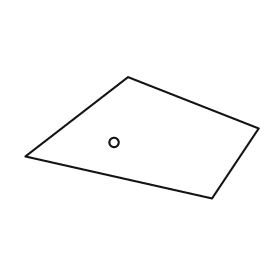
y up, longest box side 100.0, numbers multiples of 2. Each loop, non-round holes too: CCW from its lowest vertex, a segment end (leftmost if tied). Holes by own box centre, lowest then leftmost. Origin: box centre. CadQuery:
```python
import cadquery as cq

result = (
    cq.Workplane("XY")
    .moveTo(30.0, -26.0)
    .lineTo(50.0, 4.0)
    .lineTo(-6.0, 26.0)
    .lineTo(-50.0, -8.0)
    .close()
    .moveTo(-12.0, -2.0)
    .circle(2.0)
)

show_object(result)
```